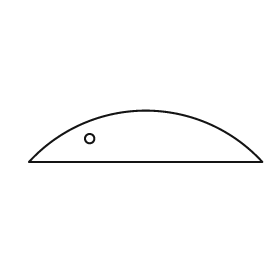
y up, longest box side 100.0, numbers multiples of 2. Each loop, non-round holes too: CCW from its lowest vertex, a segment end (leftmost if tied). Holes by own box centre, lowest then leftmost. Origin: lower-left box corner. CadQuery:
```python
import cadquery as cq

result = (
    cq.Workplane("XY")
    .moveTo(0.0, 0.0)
    .lineTo(100.0, 0.0)
    .threePointArc((50.0, 22.0), (0.0, 0.0))
    .close()
    .moveTo(26.0, 10.0)
    .circle(2.0)
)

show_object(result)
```